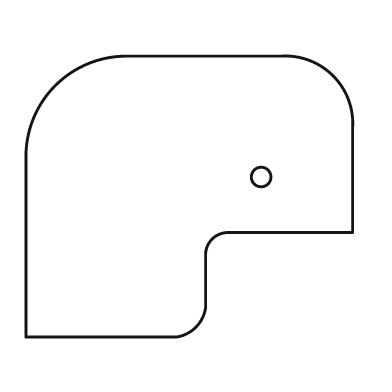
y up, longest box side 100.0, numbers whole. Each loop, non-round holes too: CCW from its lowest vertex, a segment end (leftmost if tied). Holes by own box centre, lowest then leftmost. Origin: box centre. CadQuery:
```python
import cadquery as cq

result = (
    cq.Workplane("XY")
    .moveTo(-50.0, -43.0)
    .lineTo(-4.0, -43.0)
    .threePointArc((2.0, -40.0), (5.0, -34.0))
    .lineTo(5.0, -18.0)
    .threePointArc((7.0, -13.0), (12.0, -11.0))
    .lineTo(50.0, -11.0)
    .lineTo(50.0, 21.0)
    .threePointArc((44.0, 37.0), (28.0, 43.0))
    .lineTo(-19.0, 43.0)
    .threePointArc((-41.0, 34.0), (-50.0, 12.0))
    .close()
    .moveTo(22.0, 6.0)
    .circle(3.0)
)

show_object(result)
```